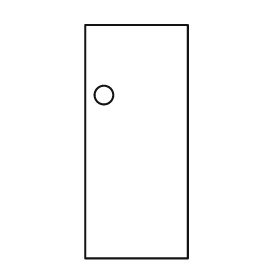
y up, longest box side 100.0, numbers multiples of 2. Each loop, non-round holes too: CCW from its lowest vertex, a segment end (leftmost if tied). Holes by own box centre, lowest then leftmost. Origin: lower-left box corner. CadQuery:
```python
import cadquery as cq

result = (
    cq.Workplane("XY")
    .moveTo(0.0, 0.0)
    .lineTo(44.0, 0.0)
    .lineTo(44.0, 100.0)
    .lineTo(0.0, 100.0)
    .close()
    .moveTo(8.0, 70.0)
    .circle(4.0)
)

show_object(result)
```